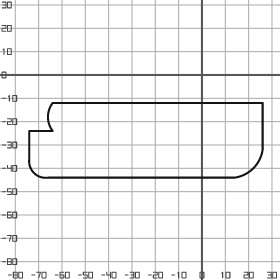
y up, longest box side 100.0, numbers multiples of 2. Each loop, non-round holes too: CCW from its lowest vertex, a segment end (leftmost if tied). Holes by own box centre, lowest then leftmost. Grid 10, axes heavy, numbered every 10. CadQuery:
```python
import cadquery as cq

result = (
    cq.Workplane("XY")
    .moveTo(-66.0, -44.0)
    .lineTo(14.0, -44.0)
    .threePointArc((22.0, -40.0), (26.0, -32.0))
    .lineTo(26.0, -12.0)
    .lineTo(-64.0, -12.0)
    .threePointArc((-66.0, -18.0), (-64.0, -24.0))
    .lineTo(-74.0, -24.0)
    .lineTo(-74.0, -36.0)
    .threePointArc((-72.0, -42.0), (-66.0, -44.0))
    .close()
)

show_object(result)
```